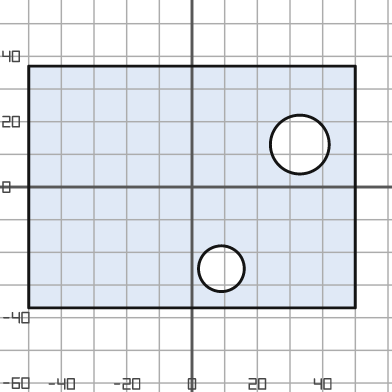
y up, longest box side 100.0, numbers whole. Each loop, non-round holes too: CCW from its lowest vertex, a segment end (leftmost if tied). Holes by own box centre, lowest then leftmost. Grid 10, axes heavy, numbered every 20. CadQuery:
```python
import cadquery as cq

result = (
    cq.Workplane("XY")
    .moveTo(-50.0, -37.0)
    .lineTo(50.0, -37.0)
    .lineTo(50.0, 37.0)
    .lineTo(-50.0, 37.0)
    .close()
    .moveTo(9.0, -25.0)
    .circle(7.0)
    .moveTo(33.0, 13.0)
    .circle(9.0)
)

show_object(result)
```